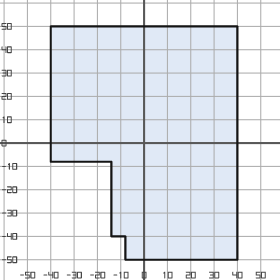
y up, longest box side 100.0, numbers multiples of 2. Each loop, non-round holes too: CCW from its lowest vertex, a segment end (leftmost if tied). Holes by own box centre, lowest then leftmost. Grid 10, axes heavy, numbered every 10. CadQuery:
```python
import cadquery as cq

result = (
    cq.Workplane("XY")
    .moveTo(-8.0, -50.0)
    .lineTo(40.0, -50.0)
    .lineTo(40.0, 50.0)
    .lineTo(-40.0, 50.0)
    .lineTo(-40.0, -8.0)
    .lineTo(-14.0, -8.0)
    .lineTo(-14.0, -40.0)
    .lineTo(-8.0, -40.0)
    .close()
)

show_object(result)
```